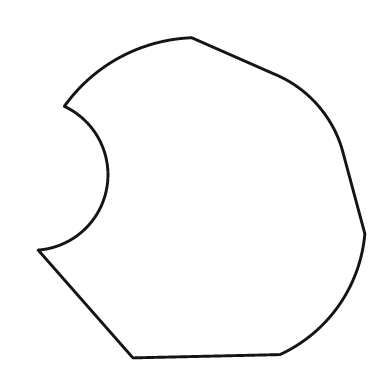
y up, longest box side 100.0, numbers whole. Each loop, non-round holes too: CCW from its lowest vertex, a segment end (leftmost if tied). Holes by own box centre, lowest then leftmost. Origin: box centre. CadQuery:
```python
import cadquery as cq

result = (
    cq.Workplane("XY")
    .moveTo(-21.0, -49.0)
    .lineTo(24.0, -48.0)
    .threePointArc((42.0, -33.0), (50.0, -11.0))
    .lineTo(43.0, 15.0)
    .threePointArc((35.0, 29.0), (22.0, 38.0))
    .lineTo(-3.0, 49.0)
    .threePointArc((-25.0, 43.0), (-42.0, 28.0))
    .threePointArc((-29.0, 3.0), (-50.0, -16.0))
    .close()
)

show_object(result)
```